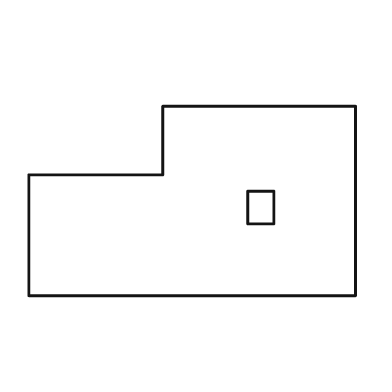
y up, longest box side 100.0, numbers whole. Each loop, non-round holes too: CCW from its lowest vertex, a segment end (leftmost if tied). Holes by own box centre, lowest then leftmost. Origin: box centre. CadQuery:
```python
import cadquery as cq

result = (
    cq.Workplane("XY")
    .moveTo(-50.0, -29.0)
    .lineTo(50.0, -29.0)
    .lineTo(50.0, 29.0)
    .lineTo(-9.0, 29.0)
    .lineTo(-9.0, 8.0)
    .lineTo(-50.0, 8.0)
    .close()
    .moveTo(17.0, -7.0)
    .lineTo(25.0, -7.0)
    .lineTo(25.0, 3.0)
    .lineTo(17.0, 3.0)
    .close()
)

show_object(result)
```